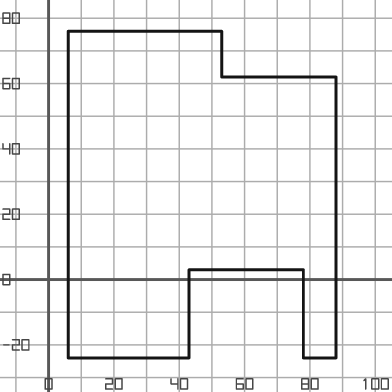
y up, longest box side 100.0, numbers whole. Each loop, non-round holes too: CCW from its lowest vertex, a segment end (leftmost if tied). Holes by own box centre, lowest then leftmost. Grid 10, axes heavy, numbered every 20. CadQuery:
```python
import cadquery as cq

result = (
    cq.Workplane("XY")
    .moveTo(6.0, -24.0)
    .lineTo(43.0, -24.0)
    .lineTo(43.0, 3.0)
    .lineTo(78.0, 3.0)
    .lineTo(78.0, -24.0)
    .lineTo(88.0, -24.0)
    .lineTo(88.0, 62.0)
    .lineTo(53.0, 62.0)
    .lineTo(53.0, 76.0)
    .lineTo(6.0, 76.0)
    .close()
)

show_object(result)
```